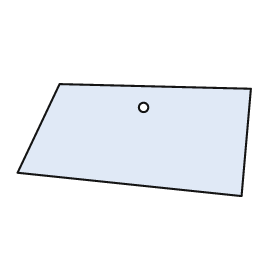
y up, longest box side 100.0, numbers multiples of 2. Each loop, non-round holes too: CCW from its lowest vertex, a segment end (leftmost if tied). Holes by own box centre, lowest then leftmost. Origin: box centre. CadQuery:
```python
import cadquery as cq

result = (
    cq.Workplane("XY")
    .moveTo(46.0, -24.0)
    .lineTo(50.0, 22.0)
    .lineTo(-32.0, 24.0)
    .lineTo(-50.0, -14.0)
    .close()
    .moveTo(4.0, 14.0)
    .circle(2.0)
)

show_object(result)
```